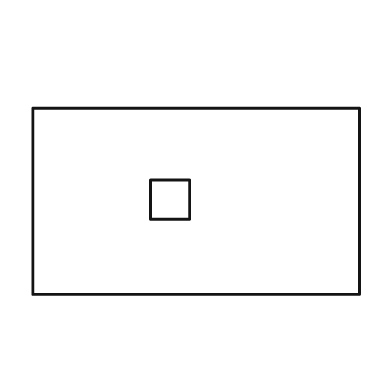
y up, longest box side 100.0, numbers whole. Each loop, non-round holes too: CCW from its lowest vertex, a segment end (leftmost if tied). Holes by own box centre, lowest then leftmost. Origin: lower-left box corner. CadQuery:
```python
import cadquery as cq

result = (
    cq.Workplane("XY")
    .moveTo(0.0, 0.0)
    .lineTo(100.0, 0.0)
    .lineTo(100.0, 57.0)
    .lineTo(0.0, 57.0)
    .close()
    .moveTo(36.0, 23.0)
    .lineTo(48.0, 23.0)
    .lineTo(48.0, 35.0)
    .lineTo(36.0, 35.0)
    .close()
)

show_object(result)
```